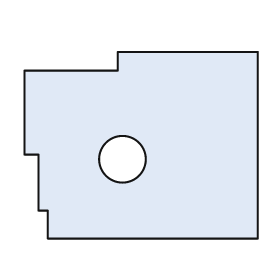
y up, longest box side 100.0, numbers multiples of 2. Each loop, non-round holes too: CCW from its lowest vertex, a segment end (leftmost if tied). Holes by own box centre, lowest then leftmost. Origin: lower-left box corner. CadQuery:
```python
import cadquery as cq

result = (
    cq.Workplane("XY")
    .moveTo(10.0, 0.0)
    .lineTo(100.0, 0.0)
    .lineTo(100.0, 80.0)
    .lineTo(40.0, 80.0)
    .lineTo(40.0, 72.0)
    .lineTo(0.0, 72.0)
    .lineTo(0.0, 36.0)
    .lineTo(6.0, 36.0)
    .lineTo(6.0, 12.0)
    .lineTo(10.0, 12.0)
    .close()
    .moveTo(42.0, 34.0)
    .circle(10.0)
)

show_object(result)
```